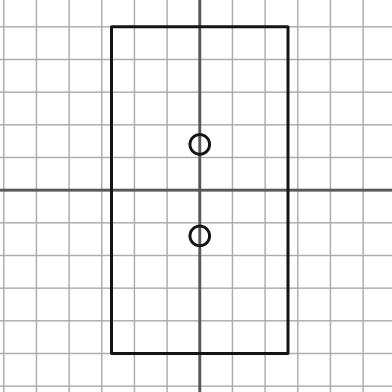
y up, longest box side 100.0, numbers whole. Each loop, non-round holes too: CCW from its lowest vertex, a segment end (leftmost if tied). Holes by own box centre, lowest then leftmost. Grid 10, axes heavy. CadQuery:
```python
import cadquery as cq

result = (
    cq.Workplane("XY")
    .moveTo(-27.0, -50.0)
    .lineTo(27.0, -50.0)
    .lineTo(27.0, 50.0)
    .lineTo(-27.0, 50.0)
    .close()
    .moveTo(0.0, -14.0)
    .circle(3.0)
    .moveTo(0.0, 14.0)
    .circle(3.0)
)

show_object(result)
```